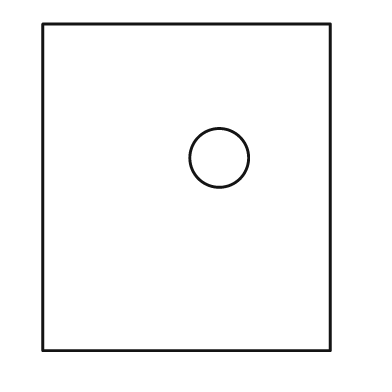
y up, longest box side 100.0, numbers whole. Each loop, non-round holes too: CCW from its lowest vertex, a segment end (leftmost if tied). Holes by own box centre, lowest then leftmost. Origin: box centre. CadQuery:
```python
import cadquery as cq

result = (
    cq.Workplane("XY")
    .moveTo(-44.0, -50.0)
    .lineTo(44.0, -50.0)
    .lineTo(44.0, 50.0)
    .lineTo(-44.0, 50.0)
    .close()
    .moveTo(10.0, 9.0)
    .circle(9.0)
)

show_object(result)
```